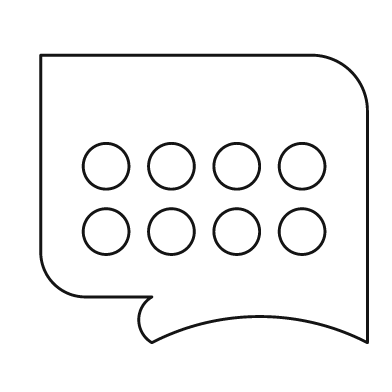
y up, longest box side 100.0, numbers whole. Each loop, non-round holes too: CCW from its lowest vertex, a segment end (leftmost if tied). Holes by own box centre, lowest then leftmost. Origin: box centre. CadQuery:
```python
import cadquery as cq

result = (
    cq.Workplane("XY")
    .moveTo(-16.0, -44.0)
    .threePointArc((17.0, -36.0), (50.0, -44.0))
    .lineTo(50.0, 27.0)
    .threePointArc((45.0, 39.0), (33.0, 44.0))
    .lineTo(-50.0, 44.0)
    .lineTo(-50.0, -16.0)
    .threePointArc((-46.0, -26.0), (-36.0, -30.0))
    .lineTo(-16.0, -30.0)
    .threePointArc((-20.0, -37.0), (-16.0, -44.0))
    .close()
    .moveTo(-30.0, -10.0)
    .circle(7.0)
    .moveTo(-10.0, -10.0)
    .circle(7.0)
    .moveTo(10.0, -10.0)
    .circle(7.0)
    .moveTo(30.0, -10.0)
    .circle(7.0)
    .moveTo(-30.0, 10.0)
    .circle(7.0)
    .moveTo(-10.0, 10.0)
    .circle(7.0)
    .moveTo(10.0, 10.0)
    .circle(7.0)
    .moveTo(30.0, 10.0)
    .circle(7.0)
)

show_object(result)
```